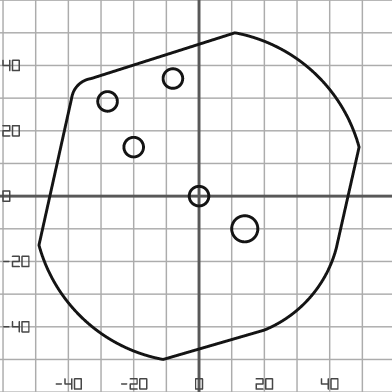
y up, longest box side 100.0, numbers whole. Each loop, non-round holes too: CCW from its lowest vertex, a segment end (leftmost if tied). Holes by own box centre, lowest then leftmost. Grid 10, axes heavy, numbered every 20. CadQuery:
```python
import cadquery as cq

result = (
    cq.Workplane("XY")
    .moveTo(-11.0, -50.0)
    .lineTo(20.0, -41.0)
    .threePointArc((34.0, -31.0), (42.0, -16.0))
    .lineTo(49.0, 15.0)
    .threePointArc((35.0, 38.0), (11.0, 50.0))
    .lineTo(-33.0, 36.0)
    .threePointArc((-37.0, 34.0), (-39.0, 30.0))
    .lineTo(-49.0, -15.0)
    .threePointArc((-35.0, -38.0), (-11.0, -50.0))
    .close()
    .moveTo(14.0, -10.0)
    .circle(4.0)
    .moveTo(0.0, 0.0)
    .circle(3.0)
    .moveTo(-20.0, 15.0)
    .circle(3.0)
    .moveTo(-28.0, 29.0)
    .circle(3.0)
    .moveTo(-8.0, 36.0)
    .circle(3.0)
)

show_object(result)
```